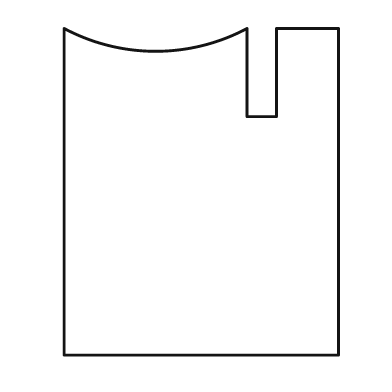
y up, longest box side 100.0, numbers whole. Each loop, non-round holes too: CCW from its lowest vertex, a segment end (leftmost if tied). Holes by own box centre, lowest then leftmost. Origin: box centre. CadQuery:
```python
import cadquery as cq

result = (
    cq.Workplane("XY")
    .moveTo(-42.0, -50.0)
    .lineTo(42.0, -50.0)
    .lineTo(42.0, 50.0)
    .lineTo(23.0, 50.0)
    .lineTo(23.0, 23.0)
    .lineTo(14.0, 23.0)
    .lineTo(14.0, 50.0)
    .threePointArc((-14.0, 43.0), (-42.0, 50.0))
    .close()
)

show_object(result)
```